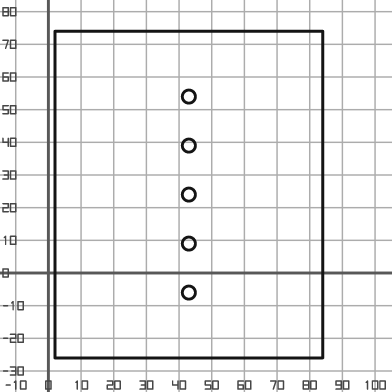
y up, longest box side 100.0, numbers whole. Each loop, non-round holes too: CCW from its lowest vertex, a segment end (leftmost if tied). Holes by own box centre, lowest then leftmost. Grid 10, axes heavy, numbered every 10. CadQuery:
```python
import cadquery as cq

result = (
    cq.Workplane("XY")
    .moveTo(2.0, -26.0)
    .lineTo(84.0, -26.0)
    .lineTo(84.0, 74.0)
    .lineTo(2.0, 74.0)
    .close()
    .moveTo(43.0, -6.0)
    .circle(2.0)
    .moveTo(43.0, 9.0)
    .circle(2.0)
    .moveTo(43.0, 24.0)
    .circle(2.0)
    .moveTo(43.0, 39.0)
    .circle(2.0)
    .moveTo(43.0, 54.0)
    .circle(2.0)
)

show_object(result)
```